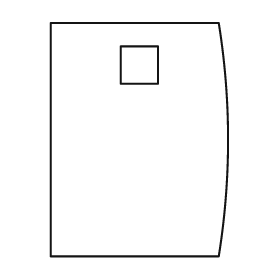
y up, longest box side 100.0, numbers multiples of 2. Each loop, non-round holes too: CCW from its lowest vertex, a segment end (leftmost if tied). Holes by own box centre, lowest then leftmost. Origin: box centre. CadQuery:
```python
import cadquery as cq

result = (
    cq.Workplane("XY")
    .moveTo(-38.0, -50.0)
    .lineTo(34.0, -50.0)
    .threePointArc((38.0, 0.0), (34.0, 50.0))
    .lineTo(-38.0, 50.0)
    .close()
    .moveTo(-8.0, 24.0)
    .lineTo(8.0, 24.0)
    .lineTo(8.0, 40.0)
    .lineTo(-8.0, 40.0)
    .close()
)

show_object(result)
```